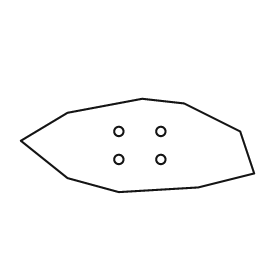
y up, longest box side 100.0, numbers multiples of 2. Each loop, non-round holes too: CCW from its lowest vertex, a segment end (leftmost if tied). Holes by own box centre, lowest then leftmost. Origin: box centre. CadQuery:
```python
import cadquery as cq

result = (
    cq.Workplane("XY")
    .moveTo(-8.0, -20.0)
    .lineTo(26.0, -18.0)
    .lineTo(50.0, -12.0)
    .lineTo(44.0, 6.0)
    .lineTo(20.0, 18.0)
    .lineTo(2.0, 20.0)
    .lineTo(-30.0, 14.0)
    .lineTo(-50.0, 2.0)
    .lineTo(-30.0, -14.0)
    .close()
    .moveTo(-8.0, -6.0)
    .circle(2.0)
    .moveTo(10.0, -6.0)
    .circle(2.0)
    .moveTo(-8.0, 6.0)
    .circle(2.0)
    .moveTo(10.0, 6.0)
    .circle(2.0)
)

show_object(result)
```